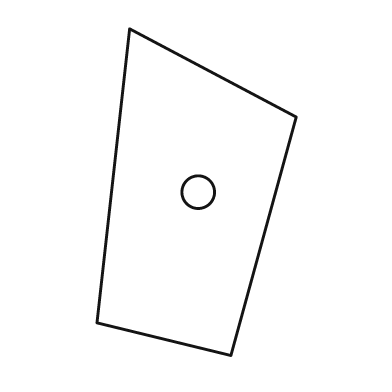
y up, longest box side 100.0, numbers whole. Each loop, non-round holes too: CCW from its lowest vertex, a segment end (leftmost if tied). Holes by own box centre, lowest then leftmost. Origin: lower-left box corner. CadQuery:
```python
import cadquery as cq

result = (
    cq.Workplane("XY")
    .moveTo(41.0, 0.0)
    .lineTo(61.0, 73.0)
    .lineTo(10.0, 100.0)
    .lineTo(0.0, 10.0)
    .close()
    .moveTo(31.0, 50.0)
    .circle(5.0)
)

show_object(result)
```